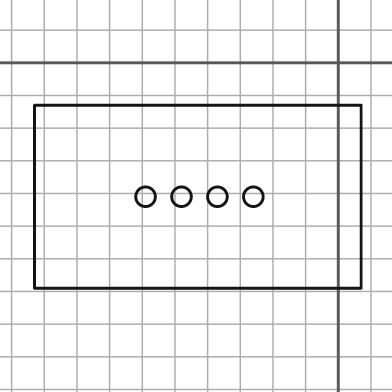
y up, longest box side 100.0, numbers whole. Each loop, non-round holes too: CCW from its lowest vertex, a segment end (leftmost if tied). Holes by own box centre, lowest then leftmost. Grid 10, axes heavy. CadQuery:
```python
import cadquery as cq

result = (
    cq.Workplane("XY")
    .moveTo(-93.0, -69.0)
    .lineTo(7.0, -69.0)
    .lineTo(7.0, -13.0)
    .lineTo(-93.0, -13.0)
    .close()
    .moveTo(-59.0, -41.0)
    .circle(3.0)
    .moveTo(-48.0, -41.0)
    .circle(3.0)
    .moveTo(-37.0, -41.0)
    .circle(3.0)
    .moveTo(-26.0, -41.0)
    .circle(3.0)
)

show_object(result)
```